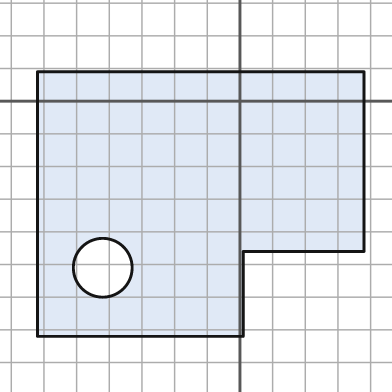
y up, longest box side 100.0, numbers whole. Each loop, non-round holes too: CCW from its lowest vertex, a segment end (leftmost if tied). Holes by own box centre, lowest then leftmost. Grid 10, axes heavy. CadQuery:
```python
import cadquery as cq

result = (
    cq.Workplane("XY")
    .moveTo(-62.0, -72.0)
    .lineTo(1.0, -72.0)
    .lineTo(1.0, -46.0)
    .lineTo(38.0, -46.0)
    .lineTo(38.0, 9.0)
    .lineTo(-62.0, 9.0)
    .close()
    .moveTo(-42.0, -51.0)
    .circle(9.0)
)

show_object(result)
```